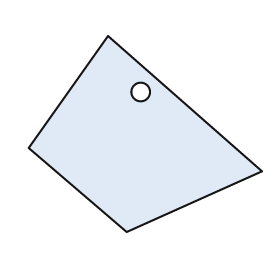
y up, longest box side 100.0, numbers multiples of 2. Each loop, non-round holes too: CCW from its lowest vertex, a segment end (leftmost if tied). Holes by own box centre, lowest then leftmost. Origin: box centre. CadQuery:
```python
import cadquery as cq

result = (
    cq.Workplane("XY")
    .moveTo(-8.0, -42.0)
    .lineTo(50.0, -16.0)
    .lineTo(-16.0, 42.0)
    .lineTo(-50.0, -6.0)
    .close()
    .moveTo(-2.0, 18.0)
    .circle(4.0)
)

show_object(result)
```